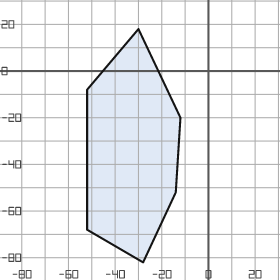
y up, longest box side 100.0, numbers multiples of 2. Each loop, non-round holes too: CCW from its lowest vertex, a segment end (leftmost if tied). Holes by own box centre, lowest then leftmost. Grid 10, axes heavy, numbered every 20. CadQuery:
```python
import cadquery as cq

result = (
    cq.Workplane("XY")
    .moveTo(-28.0, -82.0)
    .lineTo(-14.0, -52.0)
    .lineTo(-12.0, -20.0)
    .lineTo(-30.0, 18.0)
    .lineTo(-52.0, -8.0)
    .lineTo(-52.0, -68.0)
    .close()
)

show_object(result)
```